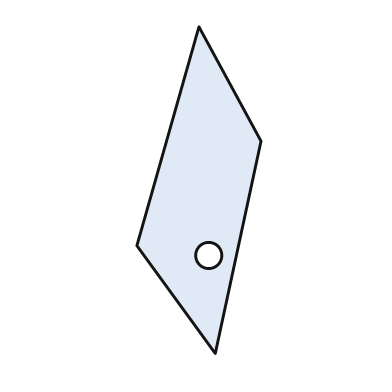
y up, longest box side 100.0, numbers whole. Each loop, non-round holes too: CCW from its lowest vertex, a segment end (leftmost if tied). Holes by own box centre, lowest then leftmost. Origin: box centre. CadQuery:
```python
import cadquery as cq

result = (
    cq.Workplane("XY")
    .moveTo(5.0, -50.0)
    .lineTo(19.0, 15.0)
    .lineTo(0.0, 50.0)
    .lineTo(-19.0, -17.0)
    .close()
    .moveTo(3.0, -20.0)
    .circle(4.0)
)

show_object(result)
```